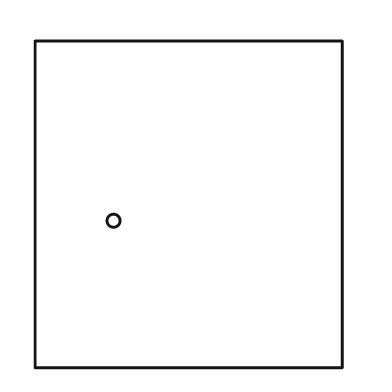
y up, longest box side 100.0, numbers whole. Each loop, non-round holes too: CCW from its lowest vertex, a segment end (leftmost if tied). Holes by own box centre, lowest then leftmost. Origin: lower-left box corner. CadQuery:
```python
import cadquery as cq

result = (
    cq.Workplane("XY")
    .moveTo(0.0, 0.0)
    .lineTo(94.0, 0.0)
    .lineTo(94.0, 100.0)
    .lineTo(0.0, 100.0)
    .close()
    .moveTo(24.0, 45.0)
    .circle(2.0)
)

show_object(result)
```